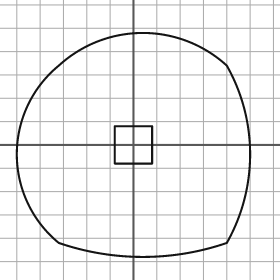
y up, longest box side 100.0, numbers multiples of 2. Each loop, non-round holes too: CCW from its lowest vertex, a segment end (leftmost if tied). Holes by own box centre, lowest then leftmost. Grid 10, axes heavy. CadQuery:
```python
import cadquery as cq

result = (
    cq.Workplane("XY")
    .moveTo(-32.0, -42.0)
    .threePointArc((4.0, -48.0), (40.0, -42.0))
    .threePointArc((50.0, -4.0), (40.0, 34.0))
    .threePointArc((4.0, 48.0), (-32.0, 34.0))
    .threePointArc((-50.0, -4.0), (-32.0, -42.0))
    .close()
    .moveTo(-8.0, -8.0)
    .lineTo(8.0, -8.0)
    .lineTo(8.0, 8.0)
    .lineTo(-8.0, 8.0)
    .close()
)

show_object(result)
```